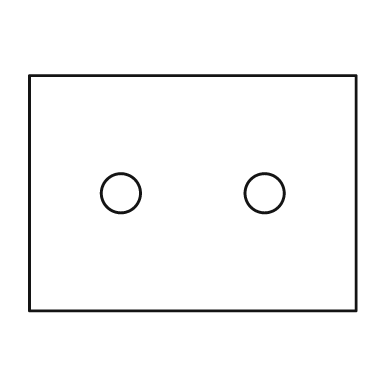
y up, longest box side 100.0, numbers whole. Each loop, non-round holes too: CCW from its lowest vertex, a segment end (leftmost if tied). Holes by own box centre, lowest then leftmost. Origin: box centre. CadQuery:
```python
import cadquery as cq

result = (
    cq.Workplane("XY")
    .moveTo(-50.0, -36.0)
    .lineTo(50.0, -36.0)
    .lineTo(50.0, 36.0)
    .lineTo(-50.0, 36.0)
    .close()
    .moveTo(-22.0, 0.0)
    .circle(6.0)
    .moveTo(22.0, 0.0)
    .circle(6.0)
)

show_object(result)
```